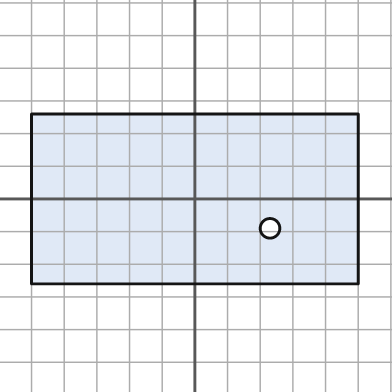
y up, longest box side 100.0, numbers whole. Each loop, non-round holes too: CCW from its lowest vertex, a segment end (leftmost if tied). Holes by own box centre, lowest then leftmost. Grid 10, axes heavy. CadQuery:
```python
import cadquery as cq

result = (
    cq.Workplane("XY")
    .moveTo(-50.0, -26.0)
    .lineTo(50.0, -26.0)
    .lineTo(50.0, 26.0)
    .lineTo(-50.0, 26.0)
    .close()
    .moveTo(23.0, -9.0)
    .circle(3.0)
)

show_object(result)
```